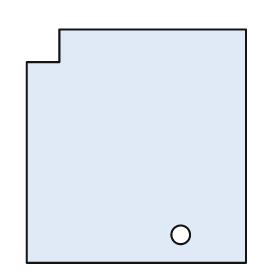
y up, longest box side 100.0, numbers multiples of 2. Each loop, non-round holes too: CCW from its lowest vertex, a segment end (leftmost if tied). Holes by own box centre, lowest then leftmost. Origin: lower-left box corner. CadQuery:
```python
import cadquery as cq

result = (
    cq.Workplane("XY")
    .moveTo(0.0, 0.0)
    .lineTo(94.0, 0.0)
    .lineTo(94.0, 100.0)
    .lineTo(14.0, 100.0)
    .lineTo(14.0, 86.0)
    .lineTo(0.0, 86.0)
    .close()
    .moveTo(66.0, 12.0)
    .circle(4.0)
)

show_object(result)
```